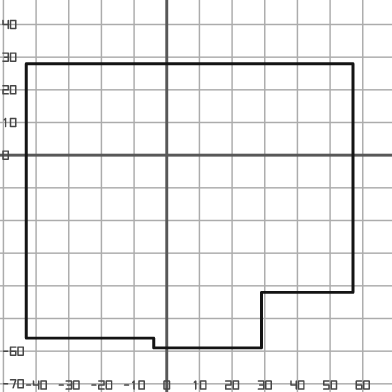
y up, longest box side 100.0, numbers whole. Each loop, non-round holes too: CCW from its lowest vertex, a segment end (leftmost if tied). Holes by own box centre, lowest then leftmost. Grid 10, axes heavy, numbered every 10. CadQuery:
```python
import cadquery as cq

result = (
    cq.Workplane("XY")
    .moveTo(-4.0, -59.0)
    .lineTo(29.0, -59.0)
    .lineTo(29.0, -42.0)
    .lineTo(57.0, -42.0)
    .lineTo(57.0, 28.0)
    .lineTo(-43.0, 28.0)
    .lineTo(-43.0, -56.0)
    .lineTo(-4.0, -56.0)
    .close()
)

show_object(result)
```